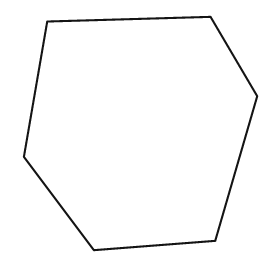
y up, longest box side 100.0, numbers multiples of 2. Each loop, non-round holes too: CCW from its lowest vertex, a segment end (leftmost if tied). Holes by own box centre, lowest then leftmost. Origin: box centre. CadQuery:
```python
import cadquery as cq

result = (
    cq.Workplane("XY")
    .moveTo(-20.0, -50.0)
    .lineTo(32.0, -46.0)
    .lineTo(50.0, 16.0)
    .lineTo(30.0, 50.0)
    .lineTo(-40.0, 48.0)
    .lineTo(-50.0, -10.0)
    .close()
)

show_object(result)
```